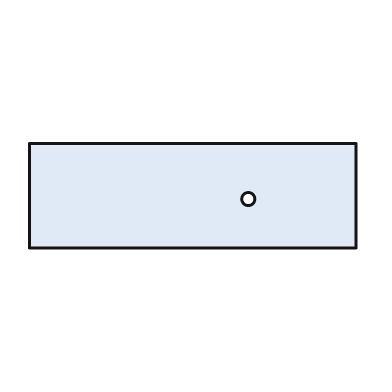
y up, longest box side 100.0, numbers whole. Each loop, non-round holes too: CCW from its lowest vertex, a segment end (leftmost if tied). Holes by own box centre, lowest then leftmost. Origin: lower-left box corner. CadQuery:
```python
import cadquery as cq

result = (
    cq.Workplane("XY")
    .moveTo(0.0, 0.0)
    .lineTo(100.0, 0.0)
    .lineTo(100.0, 32.0)
    .lineTo(0.0, 32.0)
    .close()
    .moveTo(67.0, 15.0)
    .circle(2.0)
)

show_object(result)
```